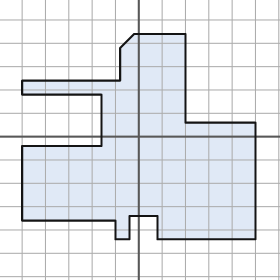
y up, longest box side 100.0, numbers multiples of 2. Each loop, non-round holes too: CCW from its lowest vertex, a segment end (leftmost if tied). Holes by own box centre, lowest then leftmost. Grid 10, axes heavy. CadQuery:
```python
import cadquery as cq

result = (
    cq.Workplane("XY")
    .moveTo(-10.0, -44.0)
    .lineTo(-4.0, -44.0)
    .lineTo(-4.0, -34.0)
    .lineTo(8.0, -34.0)
    .lineTo(8.0, -44.0)
    .lineTo(50.0, -44.0)
    .lineTo(50.0, 6.0)
    .lineTo(20.0, 6.0)
    .lineTo(20.0, 44.0)
    .lineTo(-2.0, 44.0)
    .lineTo(-8.0, 38.0)
    .lineTo(-8.0, 24.0)
    .lineTo(-50.0, 24.0)
    .lineTo(-50.0, 18.0)
    .lineTo(-16.0, 18.0)
    .lineTo(-16.0, -4.0)
    .lineTo(-50.0, -4.0)
    .lineTo(-50.0, -36.0)
    .lineTo(-10.0, -36.0)
    .close()
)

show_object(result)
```